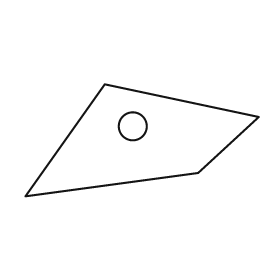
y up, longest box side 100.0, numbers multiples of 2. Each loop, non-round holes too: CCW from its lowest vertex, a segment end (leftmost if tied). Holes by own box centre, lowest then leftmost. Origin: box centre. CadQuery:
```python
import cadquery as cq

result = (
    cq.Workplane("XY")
    .moveTo(-50.0, -24.0)
    .lineTo(24.0, -14.0)
    .lineTo(50.0, 10.0)
    .lineTo(-16.0, 24.0)
    .close()
    .moveTo(-4.0, 6.0)
    .circle(6.0)
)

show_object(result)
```